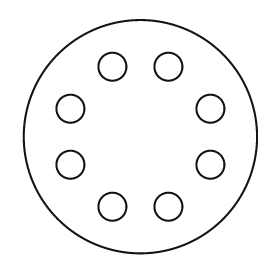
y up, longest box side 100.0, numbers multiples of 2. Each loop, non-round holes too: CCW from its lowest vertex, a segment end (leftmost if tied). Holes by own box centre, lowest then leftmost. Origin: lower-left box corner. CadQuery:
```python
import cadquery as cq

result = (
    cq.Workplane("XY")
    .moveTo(50.0, 50.0)
    .circle(50.0)
    .moveTo(38.0, 20.0)
    .circle(6.0)
    .moveTo(62.0, 20.0)
    .circle(6.0)
    .moveTo(20.0, 38.0)
    .circle(6.0)
    .moveTo(80.0, 38.0)
    .circle(6.0)
    .moveTo(20.0, 62.0)
    .circle(6.0)
    .moveTo(80.0, 62.0)
    .circle(6.0)
    .moveTo(38.0, 80.0)
    .circle(6.0)
    .moveTo(62.0, 80.0)
    .circle(6.0)
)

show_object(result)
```